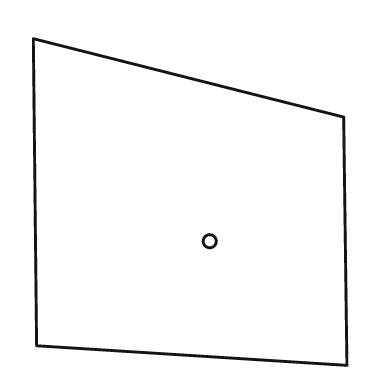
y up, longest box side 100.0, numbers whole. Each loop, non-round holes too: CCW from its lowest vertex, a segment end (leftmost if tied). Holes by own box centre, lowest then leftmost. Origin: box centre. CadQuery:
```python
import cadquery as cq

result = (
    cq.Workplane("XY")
    .moveTo(48.0, -50.0)
    .lineTo(47.0, 26.0)
    .lineTo(-48.0, 50.0)
    .lineTo(-47.0, -44.0)
    .close()
    .moveTo(6.0, -12.0)
    .circle(2.0)
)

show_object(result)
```